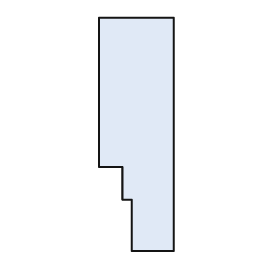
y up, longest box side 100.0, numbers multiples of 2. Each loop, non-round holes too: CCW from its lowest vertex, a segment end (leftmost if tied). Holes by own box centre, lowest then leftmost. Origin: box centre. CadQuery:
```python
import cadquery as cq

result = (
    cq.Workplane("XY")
    .moveTo(-2.0, -50.0)
    .lineTo(16.0, -50.0)
    .lineTo(16.0, 50.0)
    .lineTo(-16.0, 50.0)
    .lineTo(-16.0, -14.0)
    .lineTo(-6.0, -14.0)
    .lineTo(-6.0, -28.0)
    .lineTo(-2.0, -28.0)
    .close()
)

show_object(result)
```